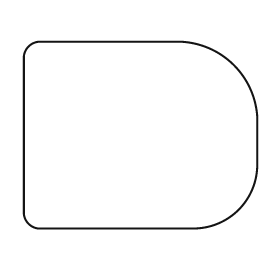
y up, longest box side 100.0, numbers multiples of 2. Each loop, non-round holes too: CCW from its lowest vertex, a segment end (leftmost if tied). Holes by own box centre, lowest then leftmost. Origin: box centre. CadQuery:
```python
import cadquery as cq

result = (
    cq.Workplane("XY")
    .moveTo(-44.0, -40.0)
    .lineTo(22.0, -40.0)
    .threePointArc((42.0, -32.0), (50.0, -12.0))
    .lineTo(50.0, 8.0)
    .threePointArc((40.0, 30.0), (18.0, 40.0))
    .lineTo(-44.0, 40.0)
    .threePointArc((-48.0, 38.0), (-50.0, 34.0))
    .lineTo(-50.0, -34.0)
    .threePointArc((-48.0, -38.0), (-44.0, -40.0))
    .close()
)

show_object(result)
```